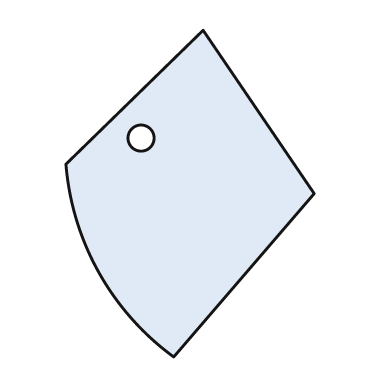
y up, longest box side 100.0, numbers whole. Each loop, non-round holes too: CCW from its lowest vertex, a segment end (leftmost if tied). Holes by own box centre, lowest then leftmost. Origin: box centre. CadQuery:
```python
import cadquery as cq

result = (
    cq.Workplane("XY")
    .moveTo(-5.0, -50.0)
    .lineTo(38.0, 0.0)
    .lineTo(4.0, 50.0)
    .lineTo(-38.0, 9.0)
    .threePointArc((-28.0, -24.0), (-5.0, -50.0))
    .close()
    .moveTo(-15.0, 17.0)
    .circle(4.0)
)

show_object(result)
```